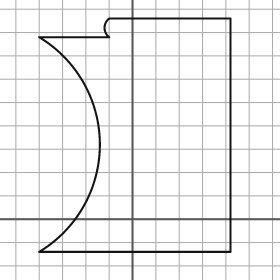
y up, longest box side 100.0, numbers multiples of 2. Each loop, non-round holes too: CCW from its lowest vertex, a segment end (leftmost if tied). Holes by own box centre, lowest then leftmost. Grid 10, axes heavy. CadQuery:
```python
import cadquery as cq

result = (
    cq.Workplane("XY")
    .moveTo(-40.0, -14.0)
    .lineTo(42.0, -14.0)
    .lineTo(42.0, 86.0)
    .lineTo(-10.0, 86.0)
    .threePointArc((-12.0, 82.0), (-10.0, 78.0))
    .lineTo(-40.0, 78.0)
    .threePointArc((-14.0, 32.0), (-40.0, -14.0))
    .close()
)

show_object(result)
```